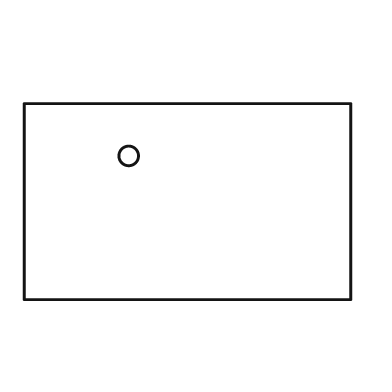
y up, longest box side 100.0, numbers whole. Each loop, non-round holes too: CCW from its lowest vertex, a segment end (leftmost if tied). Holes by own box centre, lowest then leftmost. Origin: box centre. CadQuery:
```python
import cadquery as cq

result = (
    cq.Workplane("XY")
    .moveTo(-50.0, -30.0)
    .lineTo(50.0, -30.0)
    .lineTo(50.0, 30.0)
    .lineTo(-50.0, 30.0)
    .close()
    .moveTo(-18.0, 14.0)
    .circle(3.0)
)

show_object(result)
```